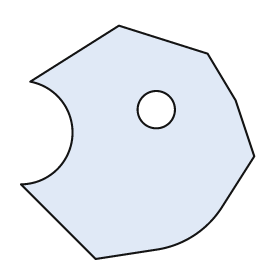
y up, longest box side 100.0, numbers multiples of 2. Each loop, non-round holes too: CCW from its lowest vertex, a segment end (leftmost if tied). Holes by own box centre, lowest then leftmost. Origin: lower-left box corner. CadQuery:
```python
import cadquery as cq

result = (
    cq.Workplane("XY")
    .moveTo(32.0, 0.0)
    .lineTo(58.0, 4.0)
    .threePointArc((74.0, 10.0), (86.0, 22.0))
    .lineTo(100.0, 44.0)
    .lineTo(92.0, 68.0)
    .lineTo(80.0, 88.0)
    .lineTo(42.0, 100.0)
    .lineTo(4.0, 76.0)
    .threePointArc((22.0, 52.0), (0.0, 32.0))
    .close()
    .moveTo(58.0, 64.0)
    .circle(8.0)
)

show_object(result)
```